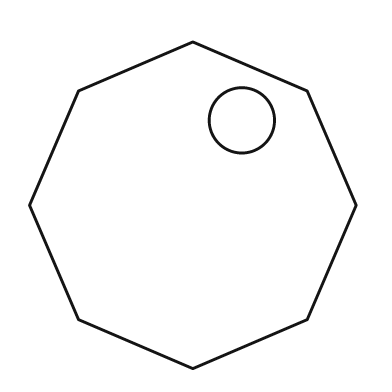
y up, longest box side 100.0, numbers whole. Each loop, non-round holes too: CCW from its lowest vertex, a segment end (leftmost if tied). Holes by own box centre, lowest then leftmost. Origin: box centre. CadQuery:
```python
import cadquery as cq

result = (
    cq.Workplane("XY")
    .moveTo(0.0, -50.0)
    .lineTo(35.0, -35.0)
    .lineTo(50.0, 0.0)
    .lineTo(35.0, 35.0)
    .lineTo(0.0, 50.0)
    .lineTo(-35.0, 35.0)
    .lineTo(-50.0, 0.0)
    .lineTo(-35.0, -35.0)
    .close()
    .moveTo(15.0, 26.0)
    .circle(10.0)
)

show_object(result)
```